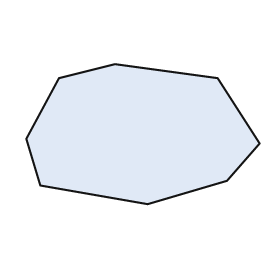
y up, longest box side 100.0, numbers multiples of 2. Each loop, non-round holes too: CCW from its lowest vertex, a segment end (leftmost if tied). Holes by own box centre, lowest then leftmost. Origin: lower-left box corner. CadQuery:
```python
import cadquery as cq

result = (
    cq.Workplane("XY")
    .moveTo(52.0, 0.0)
    .lineTo(86.0, 10.0)
    .lineTo(100.0, 26.0)
    .lineTo(82.0, 54.0)
    .lineTo(38.0, 60.0)
    .lineTo(14.0, 54.0)
    .lineTo(0.0, 28.0)
    .lineTo(6.0, 8.0)
    .close()
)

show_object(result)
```